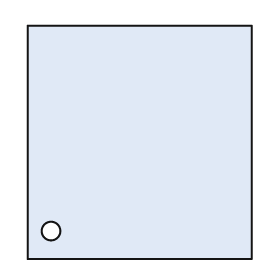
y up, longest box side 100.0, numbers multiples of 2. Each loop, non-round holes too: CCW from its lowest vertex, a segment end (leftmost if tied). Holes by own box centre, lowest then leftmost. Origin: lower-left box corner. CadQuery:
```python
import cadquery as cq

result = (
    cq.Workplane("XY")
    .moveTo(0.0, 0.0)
    .lineTo(96.0, 0.0)
    .lineTo(96.0, 100.0)
    .lineTo(0.0, 100.0)
    .close()
    .moveTo(10.0, 12.0)
    .circle(4.0)
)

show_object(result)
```